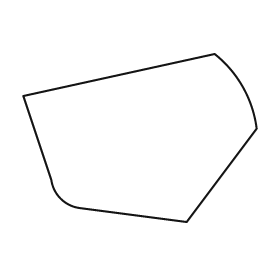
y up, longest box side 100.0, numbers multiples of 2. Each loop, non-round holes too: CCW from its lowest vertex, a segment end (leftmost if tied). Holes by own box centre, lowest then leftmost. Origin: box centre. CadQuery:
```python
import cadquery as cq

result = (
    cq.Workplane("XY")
    .moveTo(20.0, -36.0)
    .lineTo(50.0, 4.0)
    .threePointArc((44.0, 22.0), (32.0, 36.0))
    .lineTo(-50.0, 18.0)
    .lineTo(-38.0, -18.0)
    .threePointArc((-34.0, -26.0), (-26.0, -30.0))
    .close()
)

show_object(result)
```